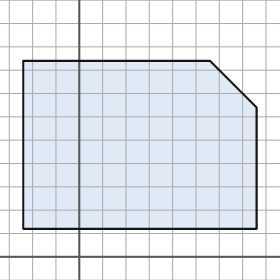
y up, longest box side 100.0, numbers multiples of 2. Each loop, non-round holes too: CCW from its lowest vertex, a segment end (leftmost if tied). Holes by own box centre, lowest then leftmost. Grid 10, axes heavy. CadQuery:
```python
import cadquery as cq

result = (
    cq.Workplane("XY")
    .moveTo(-24.0, 12.0)
    .lineTo(76.0, 12.0)
    .lineTo(76.0, 64.0)
    .lineTo(56.0, 84.0)
    .lineTo(-24.0, 84.0)
    .close()
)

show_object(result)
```